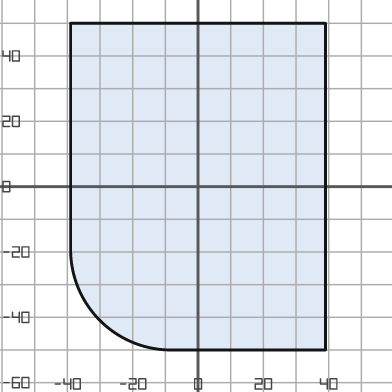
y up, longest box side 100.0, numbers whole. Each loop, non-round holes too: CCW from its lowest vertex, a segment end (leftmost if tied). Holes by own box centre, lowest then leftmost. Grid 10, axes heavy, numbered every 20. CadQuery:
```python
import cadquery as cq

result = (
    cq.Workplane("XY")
    .moveTo(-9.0, -50.0)
    .lineTo(39.0, -50.0)
    .lineTo(39.0, 50.0)
    .lineTo(-39.0, 50.0)
    .lineTo(-39.0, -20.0)
    .threePointArc((-30.0, -41.0), (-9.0, -50.0))
    .close()
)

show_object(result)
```